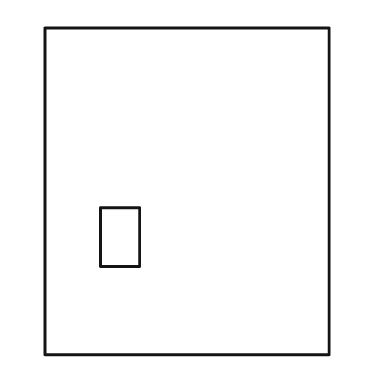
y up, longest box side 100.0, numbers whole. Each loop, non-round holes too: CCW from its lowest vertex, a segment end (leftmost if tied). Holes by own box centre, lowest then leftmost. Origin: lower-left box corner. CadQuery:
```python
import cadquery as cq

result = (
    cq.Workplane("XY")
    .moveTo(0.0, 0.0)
    .lineTo(87.0, 0.0)
    .lineTo(87.0, 100.0)
    .lineTo(0.0, 100.0)
    .close()
    .moveTo(17.0, 27.0)
    .lineTo(29.0, 27.0)
    .lineTo(29.0, 45.0)
    .lineTo(17.0, 45.0)
    .close()
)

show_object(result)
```